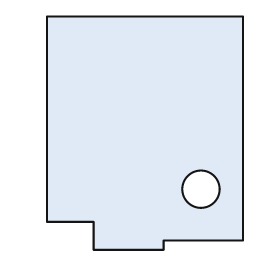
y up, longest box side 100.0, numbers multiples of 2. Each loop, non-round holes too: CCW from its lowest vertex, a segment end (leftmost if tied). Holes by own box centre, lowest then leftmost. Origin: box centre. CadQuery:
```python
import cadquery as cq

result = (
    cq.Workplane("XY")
    .moveTo(-22.0, -50.0)
    .lineTo(8.0, -50.0)
    .lineTo(8.0, -46.0)
    .lineTo(42.0, -46.0)
    .lineTo(42.0, 50.0)
    .lineTo(-42.0, 50.0)
    .lineTo(-42.0, -38.0)
    .lineTo(-22.0, -38.0)
    .close()
    .moveTo(24.0, -24.0)
    .circle(8.0)
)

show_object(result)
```